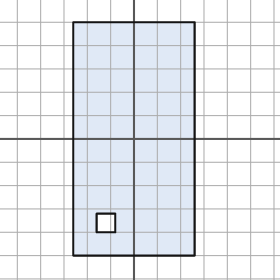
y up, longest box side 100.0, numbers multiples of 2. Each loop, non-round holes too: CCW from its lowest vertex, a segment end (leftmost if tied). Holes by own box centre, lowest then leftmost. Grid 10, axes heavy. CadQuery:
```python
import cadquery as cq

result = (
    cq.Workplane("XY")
    .moveTo(-26.0, -50.0)
    .lineTo(26.0, -50.0)
    .lineTo(26.0, 50.0)
    .lineTo(-26.0, 50.0)
    .close()
    .moveTo(-16.0, -40.0)
    .lineTo(-8.0, -40.0)
    .lineTo(-8.0, -32.0)
    .lineTo(-16.0, -32.0)
    .close()
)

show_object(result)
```